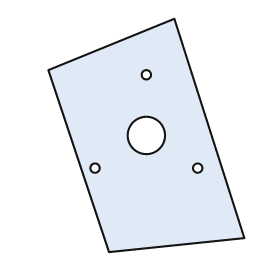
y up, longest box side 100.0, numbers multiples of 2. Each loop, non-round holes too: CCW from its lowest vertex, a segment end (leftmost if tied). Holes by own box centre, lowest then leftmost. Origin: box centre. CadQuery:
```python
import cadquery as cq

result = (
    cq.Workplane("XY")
    .moveTo(-16.0, -50.0)
    .lineTo(42.0, -44.0)
    .lineTo(12.0, 50.0)
    .lineTo(-42.0, 28.0)
    .close()
    .moveTo(-22.0, -14.0)
    .circle(2.0)
    .moveTo(22.0, -14.0)
    .circle(2.0)
    .moveTo(0.0, 0.0)
    .circle(8.0)
    .moveTo(0.0, 26.0)
    .circle(2.0)
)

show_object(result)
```